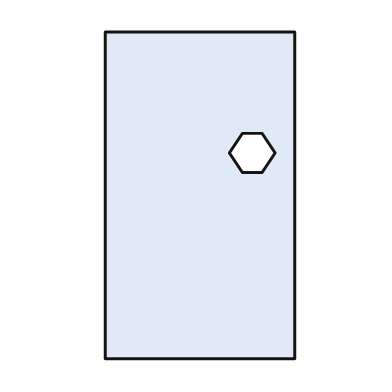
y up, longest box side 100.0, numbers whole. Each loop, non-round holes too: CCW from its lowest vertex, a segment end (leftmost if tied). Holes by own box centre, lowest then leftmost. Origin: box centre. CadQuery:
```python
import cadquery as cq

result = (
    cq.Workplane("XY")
    .moveTo(-29.0, -50.0)
    .lineTo(29.0, -50.0)
    .lineTo(29.0, 50.0)
    .lineTo(-29.0, 50.0)
    .close()
    .moveTo(13.0, 7.0)
    .lineTo(19.0, 7.0)
    .lineTo(23.0, 13.0)
    .lineTo(19.0, 19.0)
    .lineTo(13.0, 19.0)
    .lineTo(9.0, 13.0)
    .close()
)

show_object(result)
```